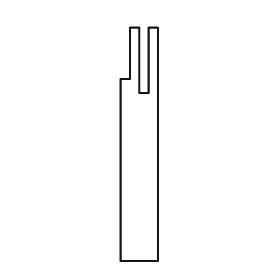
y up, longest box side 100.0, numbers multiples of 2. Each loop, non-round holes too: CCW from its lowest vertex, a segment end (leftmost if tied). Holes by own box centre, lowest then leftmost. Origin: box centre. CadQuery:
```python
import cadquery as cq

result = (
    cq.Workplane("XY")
    .moveTo(-8.0, -50.0)
    .lineTo(8.0, -50.0)
    .lineTo(8.0, 50.0)
    .lineTo(4.0, 50.0)
    .lineTo(4.0, 22.0)
    .lineTo(0.0, 22.0)
    .lineTo(0.0, 50.0)
    .lineTo(-4.0, 50.0)
    .lineTo(-4.0, 28.0)
    .lineTo(-8.0, 28.0)
    .close()
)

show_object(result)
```